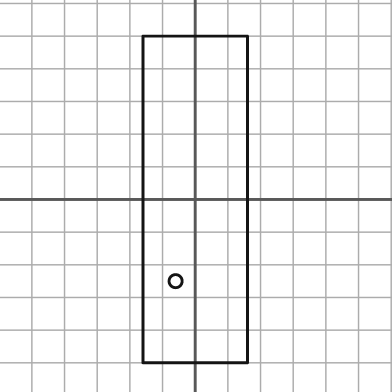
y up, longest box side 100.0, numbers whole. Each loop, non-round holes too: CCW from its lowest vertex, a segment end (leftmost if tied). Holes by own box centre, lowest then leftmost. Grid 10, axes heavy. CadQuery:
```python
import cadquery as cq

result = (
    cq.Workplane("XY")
    .moveTo(-16.0, -50.0)
    .lineTo(16.0, -50.0)
    .lineTo(16.0, 50.0)
    .lineTo(-16.0, 50.0)
    .close()
    .moveTo(-6.0, -25.0)
    .circle(2.0)
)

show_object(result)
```